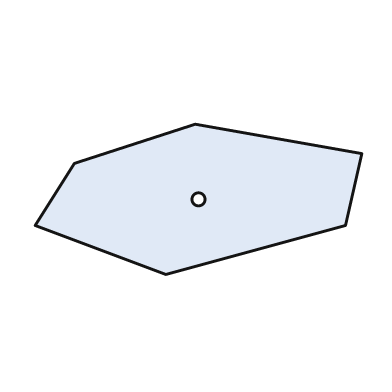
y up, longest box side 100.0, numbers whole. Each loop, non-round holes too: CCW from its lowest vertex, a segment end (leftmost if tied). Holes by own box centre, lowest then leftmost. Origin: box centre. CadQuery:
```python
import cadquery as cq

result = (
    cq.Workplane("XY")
    .moveTo(-10.0, -23.0)
    .lineTo(45.0, -8.0)
    .lineTo(50.0, 14.0)
    .lineTo(-1.0, 23.0)
    .lineTo(-38.0, 11.0)
    .lineTo(-50.0, -8.0)
    .close()
    .moveTo(0.0, 0.0)
    .circle(2.0)
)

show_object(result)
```